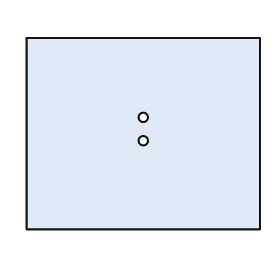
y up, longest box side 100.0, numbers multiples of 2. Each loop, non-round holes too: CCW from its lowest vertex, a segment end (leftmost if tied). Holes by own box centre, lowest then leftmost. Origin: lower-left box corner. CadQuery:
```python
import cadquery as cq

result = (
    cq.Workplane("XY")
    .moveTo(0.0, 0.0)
    .lineTo(100.0, 0.0)
    .lineTo(100.0, 82.0)
    .lineTo(0.0, 82.0)
    .close()
    .moveTo(50.0, 38.0)
    .circle(2.0)
    .moveTo(50.0, 48.0)
    .circle(2.0)
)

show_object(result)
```